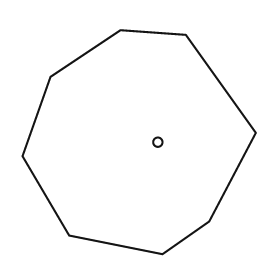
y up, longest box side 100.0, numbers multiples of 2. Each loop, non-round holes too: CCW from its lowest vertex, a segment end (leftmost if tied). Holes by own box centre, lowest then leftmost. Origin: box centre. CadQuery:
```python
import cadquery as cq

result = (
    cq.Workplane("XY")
    .moveTo(10.0, -48.0)
    .lineTo(30.0, -34.0)
    .lineTo(50.0, 4.0)
    .lineTo(20.0, 46.0)
    .lineTo(-8.0, 48.0)
    .lineTo(-38.0, 28.0)
    .lineTo(-50.0, -6.0)
    .lineTo(-30.0, -40.0)
    .close()
    .moveTo(8.0, 0.0)
    .circle(2.0)
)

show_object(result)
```